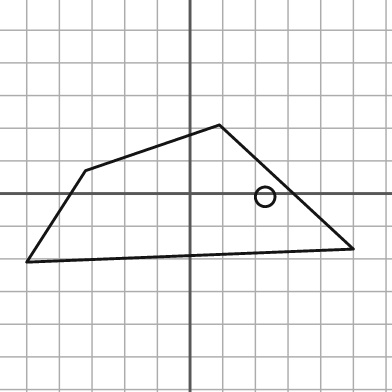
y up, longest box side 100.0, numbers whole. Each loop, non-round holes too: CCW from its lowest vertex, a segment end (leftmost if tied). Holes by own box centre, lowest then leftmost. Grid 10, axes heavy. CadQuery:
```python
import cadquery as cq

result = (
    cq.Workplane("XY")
    .moveTo(-50.0, -21.0)
    .lineTo(50.0, -17.0)
    .lineTo(9.0, 21.0)
    .lineTo(-32.0, 7.0)
    .close()
    .moveTo(23.0, -1.0)
    .circle(3.0)
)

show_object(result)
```